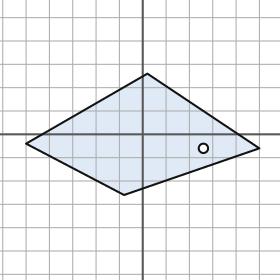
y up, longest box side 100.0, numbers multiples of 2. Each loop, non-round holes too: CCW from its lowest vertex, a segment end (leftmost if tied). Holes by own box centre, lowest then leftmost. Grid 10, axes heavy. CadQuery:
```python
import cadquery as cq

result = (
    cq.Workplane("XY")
    .moveTo(-8.0, -26.0)
    .lineTo(50.0, -6.0)
    .lineTo(2.0, 26.0)
    .lineTo(-50.0, -4.0)
    .close()
    .moveTo(26.0, -6.0)
    .circle(2.0)
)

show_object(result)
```